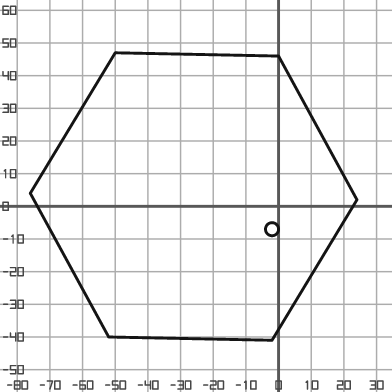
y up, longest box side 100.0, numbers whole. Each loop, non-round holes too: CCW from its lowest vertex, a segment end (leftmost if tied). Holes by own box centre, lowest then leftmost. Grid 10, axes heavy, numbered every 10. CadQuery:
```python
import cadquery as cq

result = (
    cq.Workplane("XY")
    .moveTo(-2.0, -41.0)
    .lineTo(24.0, 2.0)
    .lineTo(0.0, 46.0)
    .lineTo(-50.0, 47.0)
    .lineTo(-76.0, 4.0)
    .lineTo(-52.0, -40.0)
    .close()
    .moveTo(-2.0, -7.0)
    .circle(2.0)
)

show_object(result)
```